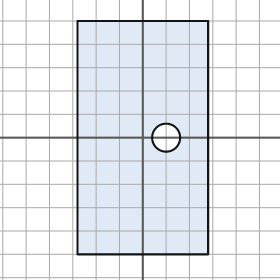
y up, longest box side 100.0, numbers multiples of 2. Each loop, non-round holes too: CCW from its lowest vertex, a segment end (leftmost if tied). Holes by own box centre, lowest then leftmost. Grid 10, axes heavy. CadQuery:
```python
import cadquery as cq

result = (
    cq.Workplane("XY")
    .moveTo(-28.0, -50.0)
    .lineTo(28.0, -50.0)
    .lineTo(28.0, 50.0)
    .lineTo(-28.0, 50.0)
    .close()
    .moveTo(10.0, 0.0)
    .circle(6.0)
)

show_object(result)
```